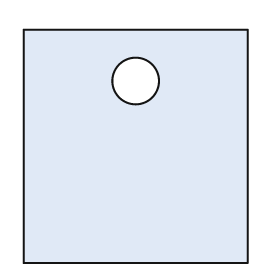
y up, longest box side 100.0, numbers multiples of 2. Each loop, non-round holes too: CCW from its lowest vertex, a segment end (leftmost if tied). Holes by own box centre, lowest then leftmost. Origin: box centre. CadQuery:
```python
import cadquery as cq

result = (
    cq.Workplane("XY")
    .moveTo(-48.0, -50.0)
    .lineTo(48.0, -50.0)
    .lineTo(48.0, 50.0)
    .lineTo(-48.0, 50.0)
    .close()
    .moveTo(0.0, 28.0)
    .circle(10.0)
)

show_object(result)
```